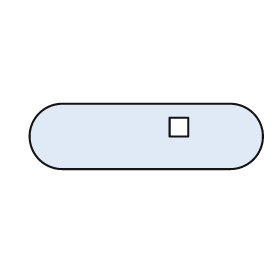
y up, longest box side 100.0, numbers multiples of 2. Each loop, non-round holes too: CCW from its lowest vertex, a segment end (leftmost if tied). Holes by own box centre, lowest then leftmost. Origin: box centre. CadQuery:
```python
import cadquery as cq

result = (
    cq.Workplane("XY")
    .moveTo(-36.0, -14.0)
    .lineTo(36.0, -14.0)
    .threePointArc((50.0, 0.0), (36.0, 14.0))
    .lineTo(-36.0, 14.0)
    .threePointArc((-50.0, 0.0), (-36.0, -14.0))
    .close()
    .moveTo(10.0, 0.0)
    .lineTo(18.0, 0.0)
    .lineTo(18.0, 8.0)
    .lineTo(10.0, 8.0)
    .close()
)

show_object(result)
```